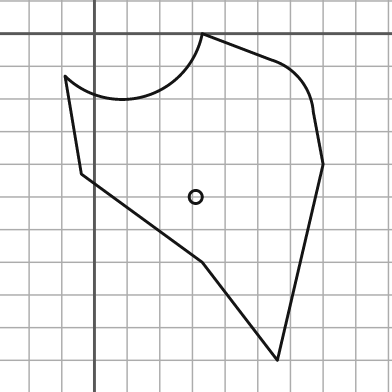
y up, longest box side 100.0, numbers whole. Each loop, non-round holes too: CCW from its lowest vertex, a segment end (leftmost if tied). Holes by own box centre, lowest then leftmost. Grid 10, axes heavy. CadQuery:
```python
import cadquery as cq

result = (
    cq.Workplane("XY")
    .moveTo(56.0, -100.0)
    .lineTo(70.0, -40.0)
    .lineTo(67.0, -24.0)
    .threePointArc((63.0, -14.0), (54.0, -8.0))
    .lineTo(33.0, 0.0)
    .threePointArc((16.0, -19.0), (-9.0, -13.0))
    .lineTo(-4.0, -43.0)
    .lineTo(33.0, -70.0)
    .close()
    .moveTo(31.0, -50.0)
    .circle(2.0)
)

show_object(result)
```